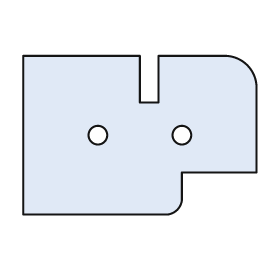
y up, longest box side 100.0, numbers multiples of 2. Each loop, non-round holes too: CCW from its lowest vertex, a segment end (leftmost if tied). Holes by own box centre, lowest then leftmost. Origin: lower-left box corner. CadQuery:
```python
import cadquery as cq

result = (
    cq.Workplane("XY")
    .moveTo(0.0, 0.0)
    .lineTo(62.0, 0.0)
    .threePointArc((66.0, 2.0), (68.0, 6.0))
    .lineTo(68.0, 18.0)
    .lineTo(100.0, 18.0)
    .lineTo(100.0, 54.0)
    .threePointArc((96.0, 64.0), (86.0, 68.0))
    .lineTo(58.0, 68.0)
    .lineTo(58.0, 48.0)
    .lineTo(50.0, 48.0)
    .lineTo(50.0, 68.0)
    .lineTo(0.0, 68.0)
    .close()
    .moveTo(32.0, 34.0)
    .circle(4.0)
    .moveTo(68.0, 34.0)
    .circle(4.0)
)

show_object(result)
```